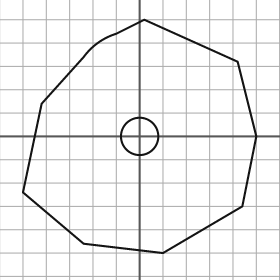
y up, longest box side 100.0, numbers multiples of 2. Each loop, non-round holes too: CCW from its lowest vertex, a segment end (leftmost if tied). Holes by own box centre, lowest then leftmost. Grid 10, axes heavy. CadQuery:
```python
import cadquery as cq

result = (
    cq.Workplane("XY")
    .moveTo(10.0, -50.0)
    .lineTo(44.0, -30.0)
    .lineTo(50.0, 0.0)
    .lineTo(42.0, 32.0)
    .lineTo(2.0, 50.0)
    .lineTo(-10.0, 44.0)
    .threePointArc((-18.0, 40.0), (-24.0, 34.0))
    .lineTo(-42.0, 14.0)
    .lineTo(-50.0, -24.0)
    .lineTo(-24.0, -46.0)
    .close()
    .moveTo(0.0, 0.0)
    .circle(8.0)
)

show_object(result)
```